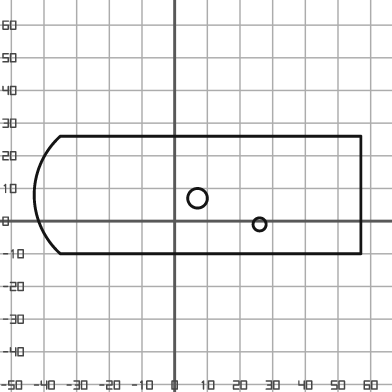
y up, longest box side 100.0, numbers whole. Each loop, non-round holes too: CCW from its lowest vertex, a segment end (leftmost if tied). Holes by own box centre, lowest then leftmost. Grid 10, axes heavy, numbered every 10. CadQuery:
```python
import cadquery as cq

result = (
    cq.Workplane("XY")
    .moveTo(-35.0, -10.0)
    .lineTo(57.0, -10.0)
    .lineTo(57.0, 26.0)
    .lineTo(-35.0, 26.0)
    .threePointArc((-43.0, 8.0), (-35.0, -10.0))
    .close()
    .moveTo(26.0, -1.0)
    .circle(2.0)
    .moveTo(7.0, 7.0)
    .circle(3.0)
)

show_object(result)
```